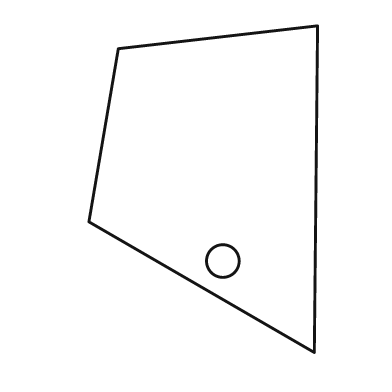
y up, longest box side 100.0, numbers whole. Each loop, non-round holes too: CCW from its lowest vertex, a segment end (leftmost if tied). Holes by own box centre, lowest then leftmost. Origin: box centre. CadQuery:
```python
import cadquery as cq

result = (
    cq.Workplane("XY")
    .moveTo(34.0, -50.0)
    .lineTo(35.0, 50.0)
    .lineTo(-26.0, 43.0)
    .lineTo(-35.0, -10.0)
    .close()
    .moveTo(6.0, -22.0)
    .circle(5.0)
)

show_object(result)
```